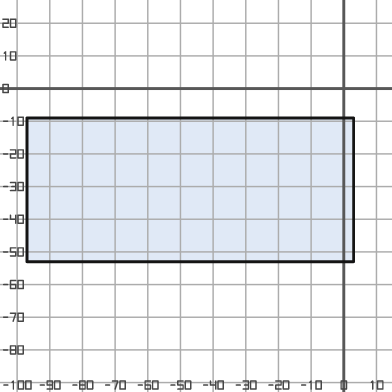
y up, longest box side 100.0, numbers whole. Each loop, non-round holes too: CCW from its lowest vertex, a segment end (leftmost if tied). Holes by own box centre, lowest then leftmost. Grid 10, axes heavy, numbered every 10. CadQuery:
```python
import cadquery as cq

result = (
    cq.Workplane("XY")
    .moveTo(-97.0, -53.0)
    .lineTo(3.0, -53.0)
    .lineTo(3.0, -9.0)
    .lineTo(-97.0, -9.0)
    .close()
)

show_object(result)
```